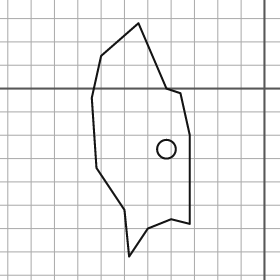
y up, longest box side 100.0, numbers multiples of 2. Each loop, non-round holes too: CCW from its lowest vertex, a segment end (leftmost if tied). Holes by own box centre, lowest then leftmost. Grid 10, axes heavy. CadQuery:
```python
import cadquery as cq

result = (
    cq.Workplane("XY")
    .moveTo(-58.0, -72.0)
    .lineTo(-50.0, -60.0)
    .lineTo(-40.0, -56.0)
    .lineTo(-32.0, -58.0)
    .lineTo(-32.0, -20.0)
    .lineTo(-36.0, -2.0)
    .lineTo(-42.0, 0.0)
    .lineTo(-54.0, 28.0)
    .lineTo(-70.0, 14.0)
    .lineTo(-74.0, -4.0)
    .lineTo(-72.0, -34.0)
    .lineTo(-60.0, -52.0)
    .close()
    .moveTo(-42.0, -26.0)
    .circle(4.0)
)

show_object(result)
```